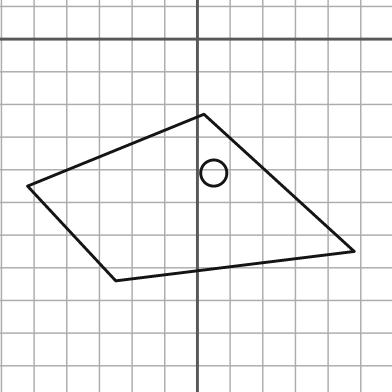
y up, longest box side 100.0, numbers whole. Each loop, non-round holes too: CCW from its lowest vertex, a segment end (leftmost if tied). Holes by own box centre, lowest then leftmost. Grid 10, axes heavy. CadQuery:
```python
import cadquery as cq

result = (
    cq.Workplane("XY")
    .moveTo(-25.0, -74.0)
    .lineTo(48.0, -65.0)
    .lineTo(2.0, -23.0)
    .lineTo(-52.0, -45.0)
    .close()
    .moveTo(5.0, -41.0)
    .circle(4.0)
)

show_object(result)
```